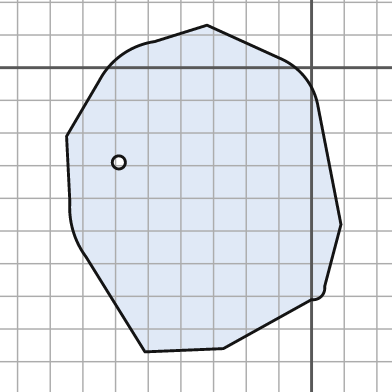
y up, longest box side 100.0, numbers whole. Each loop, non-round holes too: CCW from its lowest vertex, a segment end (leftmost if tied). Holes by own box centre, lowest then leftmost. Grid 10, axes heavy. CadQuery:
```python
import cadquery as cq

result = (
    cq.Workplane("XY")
    .moveTo(-51.0, -87.0)
    .lineTo(-27.0, -86.0)
    .lineTo(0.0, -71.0)
    .threePointArc((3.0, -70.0), (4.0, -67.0))
    .lineTo(9.0, -48.0)
    .lineTo(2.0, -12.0)
    .threePointArc((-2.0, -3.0), (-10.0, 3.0))
    .lineTo(-32.0, 13.0)
    .lineTo(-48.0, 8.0)
    .threePointArc((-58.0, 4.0), (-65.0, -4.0))
    .lineTo(-75.0, -21.0)
    .lineTo(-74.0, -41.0)
    .threePointArc((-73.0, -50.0), (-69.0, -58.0))
    .close()
    .moveTo(-59.0, -29.0)
    .circle(2.0)
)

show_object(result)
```